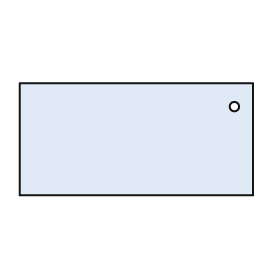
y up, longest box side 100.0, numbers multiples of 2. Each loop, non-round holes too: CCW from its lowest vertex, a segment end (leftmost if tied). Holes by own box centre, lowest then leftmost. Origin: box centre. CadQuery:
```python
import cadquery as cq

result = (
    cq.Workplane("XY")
    .moveTo(-50.0, -24.0)
    .lineTo(50.0, -24.0)
    .lineTo(50.0, 24.0)
    .lineTo(-50.0, 24.0)
    .close()
    .moveTo(42.0, 14.0)
    .circle(2.0)
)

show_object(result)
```